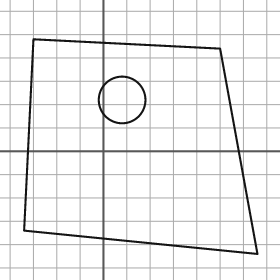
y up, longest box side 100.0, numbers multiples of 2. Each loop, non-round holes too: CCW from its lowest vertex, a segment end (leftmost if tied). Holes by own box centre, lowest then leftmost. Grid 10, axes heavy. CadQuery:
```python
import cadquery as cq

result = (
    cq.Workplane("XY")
    .moveTo(66.0, -44.0)
    .lineTo(50.0, 44.0)
    .lineTo(-30.0, 48.0)
    .lineTo(-34.0, -34.0)
    .close()
    .moveTo(8.0, 22.0)
    .circle(10.0)
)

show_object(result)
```